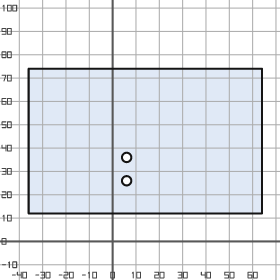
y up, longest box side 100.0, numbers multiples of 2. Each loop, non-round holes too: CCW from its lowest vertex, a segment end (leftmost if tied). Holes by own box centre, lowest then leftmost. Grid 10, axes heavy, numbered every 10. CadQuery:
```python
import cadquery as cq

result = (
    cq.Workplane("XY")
    .moveTo(-36.0, 12.0)
    .lineTo(64.0, 12.0)
    .lineTo(64.0, 74.0)
    .lineTo(-36.0, 74.0)
    .close()
    .moveTo(6.0, 26.0)
    .circle(2.0)
    .moveTo(6.0, 36.0)
    .circle(2.0)
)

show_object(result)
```